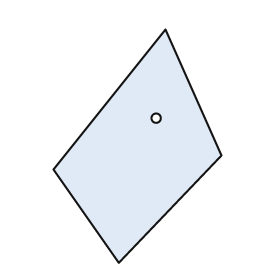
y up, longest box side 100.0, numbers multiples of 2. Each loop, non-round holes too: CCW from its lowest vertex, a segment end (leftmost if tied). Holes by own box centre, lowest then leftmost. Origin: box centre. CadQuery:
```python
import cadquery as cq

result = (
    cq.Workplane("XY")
    .moveTo(-8.0, -50.0)
    .lineTo(36.0, -4.0)
    .lineTo(12.0, 50.0)
    .lineTo(-36.0, -10.0)
    .close()
    .moveTo(8.0, 12.0)
    .circle(2.0)
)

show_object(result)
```